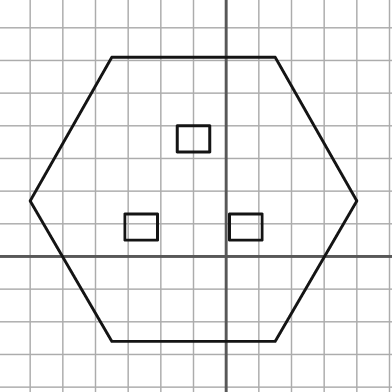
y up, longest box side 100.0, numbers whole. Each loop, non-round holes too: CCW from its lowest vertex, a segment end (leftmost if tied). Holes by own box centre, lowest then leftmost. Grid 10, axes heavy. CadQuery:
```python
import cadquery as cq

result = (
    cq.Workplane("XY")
    .moveTo(-35.0, -26.0)
    .lineTo(15.0, -26.0)
    .lineTo(40.0, 17.0)
    .lineTo(15.0, 61.0)
    .lineTo(-35.0, 61.0)
    .lineTo(-60.0, 17.0)
    .close()
    .moveTo(-31.0, 5.0)
    .lineTo(-21.0, 5.0)
    .lineTo(-21.0, 13.0)
    .lineTo(-31.0, 13.0)
    .close()
    .moveTo(1.0, 5.0)
    .lineTo(11.0, 5.0)
    .lineTo(11.0, 13.0)
    .lineTo(1.0, 13.0)
    .close()
    .moveTo(-15.0, 32.0)
    .lineTo(-5.0, 32.0)
    .lineTo(-5.0, 40.0)
    .lineTo(-15.0, 40.0)
    .close()
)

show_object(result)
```